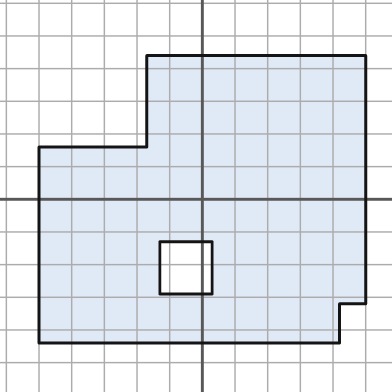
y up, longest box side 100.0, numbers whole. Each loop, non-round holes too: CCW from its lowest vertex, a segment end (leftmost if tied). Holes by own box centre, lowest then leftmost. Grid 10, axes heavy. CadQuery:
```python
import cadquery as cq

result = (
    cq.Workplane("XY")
    .moveTo(-50.0, -44.0)
    .lineTo(42.0, -44.0)
    .lineTo(42.0, -32.0)
    .lineTo(50.0, -32.0)
    .lineTo(50.0, 44.0)
    .lineTo(-17.0, 44.0)
    .lineTo(-17.0, 16.0)
    .lineTo(-50.0, 16.0)
    .close()
    .moveTo(-13.0, -29.0)
    .lineTo(3.0, -29.0)
    .lineTo(3.0, -13.0)
    .lineTo(-13.0, -13.0)
    .close()
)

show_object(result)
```